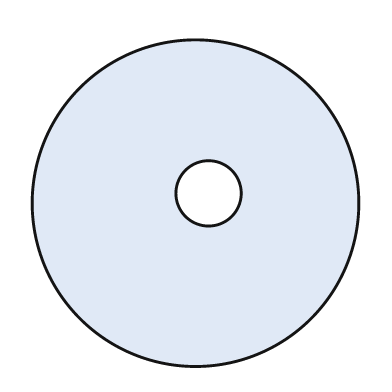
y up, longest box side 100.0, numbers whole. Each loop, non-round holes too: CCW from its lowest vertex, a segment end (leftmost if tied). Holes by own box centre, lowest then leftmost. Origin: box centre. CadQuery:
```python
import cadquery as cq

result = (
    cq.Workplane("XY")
    .moveTo(0.0, 0.0)
    .circle(50.0)
    .moveTo(4.0, 3.0)
    .circle(10.0)
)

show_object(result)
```